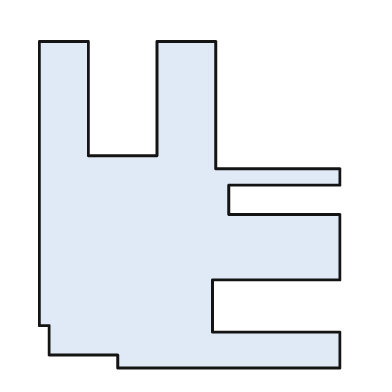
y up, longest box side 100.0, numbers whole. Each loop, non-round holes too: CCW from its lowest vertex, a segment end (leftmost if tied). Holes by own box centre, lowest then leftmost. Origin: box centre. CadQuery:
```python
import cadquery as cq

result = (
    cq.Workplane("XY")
    .moveTo(-22.0, -50.0)
    .lineTo(46.0, -50.0)
    .lineTo(46.0, -39.0)
    .lineTo(7.0, -39.0)
    .lineTo(7.0, -23.0)
    .lineTo(46.0, -23.0)
    .lineTo(46.0, -3.0)
    .lineTo(12.0, -3.0)
    .lineTo(12.0, 6.0)
    .lineTo(46.0, 6.0)
    .lineTo(46.0, 11.0)
    .lineTo(8.0, 11.0)
    .lineTo(8.0, 50.0)
    .lineTo(-10.0, 50.0)
    .lineTo(-10.0, 15.0)
    .lineTo(-31.0, 15.0)
    .lineTo(-31.0, 50.0)
    .lineTo(-46.0, 50.0)
    .lineTo(-46.0, -37.0)
    .lineTo(-43.0, -37.0)
    .lineTo(-43.0, -46.0)
    .lineTo(-22.0, -46.0)
    .close()
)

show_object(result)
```